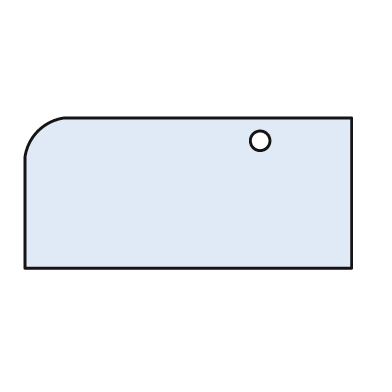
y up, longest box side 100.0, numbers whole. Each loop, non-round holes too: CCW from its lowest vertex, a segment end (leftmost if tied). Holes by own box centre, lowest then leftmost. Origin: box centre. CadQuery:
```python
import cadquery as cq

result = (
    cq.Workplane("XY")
    .moveTo(-50.0, -23.0)
    .lineTo(50.0, -23.0)
    .lineTo(50.0, 23.0)
    .lineTo(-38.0, 23.0)
    .threePointArc((-46.0, 19.0), (-50.0, 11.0))
    .close()
    .moveTo(22.0, 16.0)
    .circle(3.0)
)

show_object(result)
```